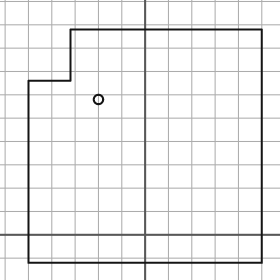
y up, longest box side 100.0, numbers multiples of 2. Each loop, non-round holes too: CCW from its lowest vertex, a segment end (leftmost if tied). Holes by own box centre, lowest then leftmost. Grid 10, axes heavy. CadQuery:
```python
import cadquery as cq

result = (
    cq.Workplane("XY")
    .moveTo(-50.0, -12.0)
    .lineTo(50.0, -12.0)
    .lineTo(50.0, 88.0)
    .lineTo(-32.0, 88.0)
    .lineTo(-32.0, 66.0)
    .lineTo(-50.0, 66.0)
    .close()
    .moveTo(-20.0, 58.0)
    .circle(2.0)
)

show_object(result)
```